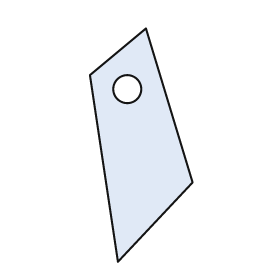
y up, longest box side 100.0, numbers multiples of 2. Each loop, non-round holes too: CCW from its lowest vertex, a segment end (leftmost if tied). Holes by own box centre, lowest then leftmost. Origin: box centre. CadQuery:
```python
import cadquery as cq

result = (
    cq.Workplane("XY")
    .moveTo(-10.0, -50.0)
    .lineTo(22.0, -16.0)
    .lineTo(2.0, 50.0)
    .lineTo(-22.0, 30.0)
    .close()
    .moveTo(-6.0, 24.0)
    .circle(6.0)
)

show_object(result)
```